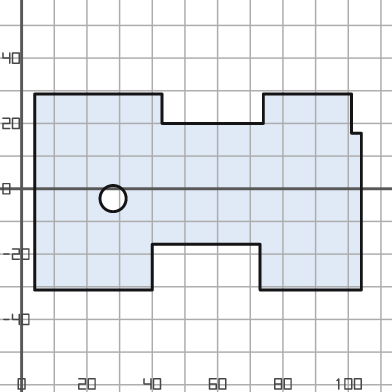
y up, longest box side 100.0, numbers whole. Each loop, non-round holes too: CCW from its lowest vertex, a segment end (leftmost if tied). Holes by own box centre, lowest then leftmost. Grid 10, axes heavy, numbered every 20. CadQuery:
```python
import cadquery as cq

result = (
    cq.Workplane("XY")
    .moveTo(4.0, -31.0)
    .lineTo(40.0, -31.0)
    .lineTo(40.0, -17.0)
    .lineTo(73.0, -17.0)
    .lineTo(73.0, -31.0)
    .lineTo(104.0, -31.0)
    .lineTo(104.0, 17.0)
    .lineTo(101.0, 17.0)
    .lineTo(101.0, 29.0)
    .lineTo(74.0, 29.0)
    .lineTo(74.0, 20.0)
    .lineTo(43.0, 20.0)
    .lineTo(43.0, 29.0)
    .lineTo(4.0, 29.0)
    .close()
    .moveTo(28.0, -3.0)
    .circle(4.0)
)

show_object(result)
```